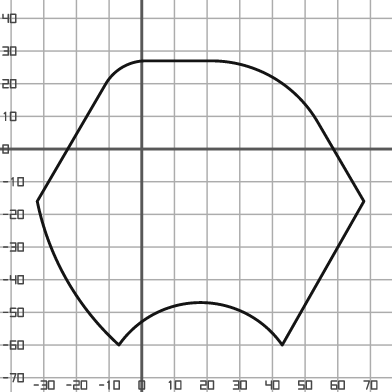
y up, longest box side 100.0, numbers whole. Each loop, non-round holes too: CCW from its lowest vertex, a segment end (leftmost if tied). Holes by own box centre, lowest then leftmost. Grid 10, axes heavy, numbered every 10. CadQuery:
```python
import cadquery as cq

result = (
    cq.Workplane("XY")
    .moveTo(-7.0, -60.0)
    .threePointArc((18.0, -47.0), (43.0, -60.0))
    .lineTo(68.0, -16.0)
    .lineTo(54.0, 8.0)
    .threePointArc((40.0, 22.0), (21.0, 27.0))
    .lineTo(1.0, 27.0)
    .threePointArc((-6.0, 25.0), (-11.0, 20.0))
    .lineTo(-32.0, -16.0)
    .threePointArc((-23.0, -40.0), (-7.0, -60.0))
    .close()
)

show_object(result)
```